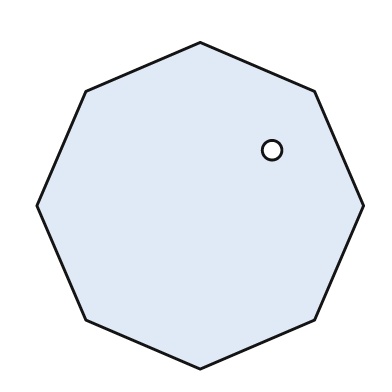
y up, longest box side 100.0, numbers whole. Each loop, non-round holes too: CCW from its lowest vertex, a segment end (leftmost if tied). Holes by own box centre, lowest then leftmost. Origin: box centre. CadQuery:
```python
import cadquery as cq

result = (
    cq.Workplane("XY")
    .moveTo(0.0, -50.0)
    .lineTo(35.0, -35.0)
    .lineTo(50.0, 0.0)
    .lineTo(35.0, 35.0)
    .lineTo(0.0, 50.0)
    .lineTo(-35.0, 35.0)
    .lineTo(-50.0, 0.0)
    .lineTo(-35.0, -35.0)
    .close()
    .moveTo(22.0, 17.0)
    .circle(3.0)
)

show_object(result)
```